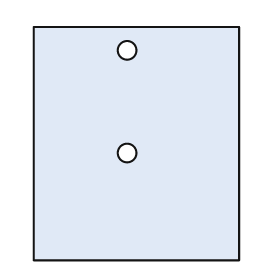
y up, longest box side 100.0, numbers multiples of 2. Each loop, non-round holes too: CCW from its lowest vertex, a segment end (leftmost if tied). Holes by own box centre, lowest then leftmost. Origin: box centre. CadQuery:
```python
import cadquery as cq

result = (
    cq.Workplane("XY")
    .moveTo(-44.0, -50.0)
    .lineTo(44.0, -50.0)
    .lineTo(44.0, 50.0)
    .lineTo(-44.0, 50.0)
    .close()
    .moveTo(-4.0, -4.0)
    .circle(4.0)
    .moveTo(-4.0, 40.0)
    .circle(4.0)
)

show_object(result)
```